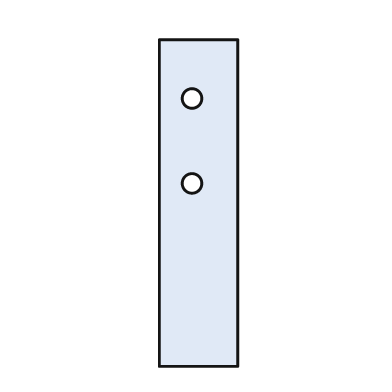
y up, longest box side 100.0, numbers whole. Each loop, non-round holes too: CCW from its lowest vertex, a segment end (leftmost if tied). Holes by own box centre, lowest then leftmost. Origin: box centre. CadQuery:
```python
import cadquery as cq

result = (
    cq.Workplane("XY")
    .moveTo(-12.0, -50.0)
    .lineTo(12.0, -50.0)
    .lineTo(12.0, 50.0)
    .lineTo(-12.0, 50.0)
    .close()
    .moveTo(-2.0, 6.0)
    .circle(3.0)
    .moveTo(-2.0, 32.0)
    .circle(3.0)
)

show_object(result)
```